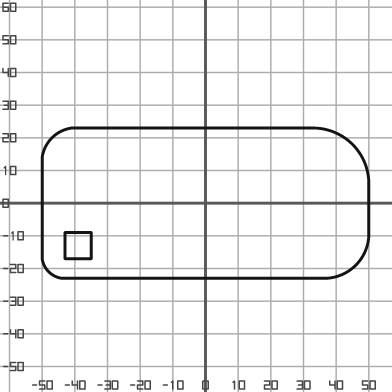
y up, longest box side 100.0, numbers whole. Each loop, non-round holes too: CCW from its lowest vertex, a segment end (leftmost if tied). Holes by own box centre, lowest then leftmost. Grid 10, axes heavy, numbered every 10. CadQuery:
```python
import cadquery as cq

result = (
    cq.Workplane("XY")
    .moveTo(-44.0, -23.0)
    .lineTo(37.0, -23.0)
    .threePointArc((46.0, -19.0), (50.0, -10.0))
    .lineTo(50.0, 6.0)
    .threePointArc((45.0, 18.0), (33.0, 23.0))
    .lineTo(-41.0, 23.0)
    .threePointArc((-47.0, 20.0), (-50.0, 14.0))
    .lineTo(-50.0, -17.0)
    .threePointArc((-48.0, -21.0), (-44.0, -23.0))
    .close()
    .moveTo(-43.0, -17.0)
    .lineTo(-35.0, -17.0)
    .lineTo(-35.0, -9.0)
    .lineTo(-43.0, -9.0)
    .close()
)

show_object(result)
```